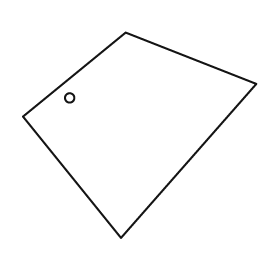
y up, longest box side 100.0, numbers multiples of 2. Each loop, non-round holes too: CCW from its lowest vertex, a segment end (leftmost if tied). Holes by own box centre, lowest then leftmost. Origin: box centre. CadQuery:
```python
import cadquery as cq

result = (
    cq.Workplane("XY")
    .moveTo(-8.0, -44.0)
    .lineTo(50.0, 22.0)
    .lineTo(-6.0, 44.0)
    .lineTo(-50.0, 8.0)
    .close()
    .moveTo(-30.0, 16.0)
    .circle(2.0)
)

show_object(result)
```